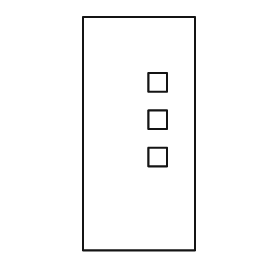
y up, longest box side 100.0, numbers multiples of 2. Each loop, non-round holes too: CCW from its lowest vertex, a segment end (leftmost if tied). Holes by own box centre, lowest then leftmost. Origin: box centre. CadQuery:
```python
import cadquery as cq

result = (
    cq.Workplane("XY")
    .moveTo(-24.0, -50.0)
    .lineTo(24.0, -50.0)
    .lineTo(24.0, 50.0)
    .lineTo(-24.0, 50.0)
    .close()
    .moveTo(4.0, -14.0)
    .lineTo(12.0, -14.0)
    .lineTo(12.0, -6.0)
    .lineTo(4.0, -6.0)
    .close()
    .moveTo(4.0, 2.0)
    .lineTo(12.0, 2.0)
    .lineTo(12.0, 10.0)
    .lineTo(4.0, 10.0)
    .close()
    .moveTo(4.0, 18.0)
    .lineTo(12.0, 18.0)
    .lineTo(12.0, 26.0)
    .lineTo(4.0, 26.0)
    .close()
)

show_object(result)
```